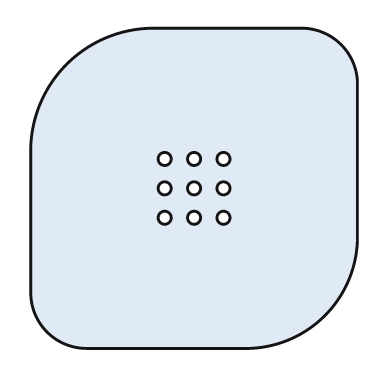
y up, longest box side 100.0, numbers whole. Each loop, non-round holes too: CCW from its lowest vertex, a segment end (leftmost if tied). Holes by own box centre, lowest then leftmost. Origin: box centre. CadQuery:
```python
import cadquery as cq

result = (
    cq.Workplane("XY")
    .moveTo(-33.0, -49.0)
    .lineTo(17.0, -49.0)
    .threePointArc((40.0, -39.0), (50.0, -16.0))
    .lineTo(50.0, 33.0)
    .threePointArc((45.0, 44.0), (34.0, 49.0))
    .lineTo(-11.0, 49.0)
    .threePointArc((-39.0, 38.0), (-50.0, 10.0))
    .lineTo(-50.0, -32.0)
    .threePointArc((-45.0, -44.0), (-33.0, -49.0))
    .close()
    .moveTo(-9.0, -9.0)
    .circle(2.0)
    .moveTo(0.0, -9.0)
    .circle(2.0)
    .moveTo(9.0, -9.0)
    .circle(2.0)
    .moveTo(-9.0, 0.0)
    .circle(2.0)
    .moveTo(0.0, 0.0)
    .circle(2.0)
    .moveTo(9.0, 0.0)
    .circle(2.0)
    .moveTo(-9.0, 9.0)
    .circle(2.0)
    .moveTo(0.0, 9.0)
    .circle(2.0)
    .moveTo(9.0, 9.0)
    .circle(2.0)
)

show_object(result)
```